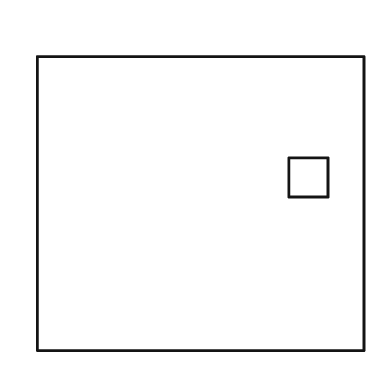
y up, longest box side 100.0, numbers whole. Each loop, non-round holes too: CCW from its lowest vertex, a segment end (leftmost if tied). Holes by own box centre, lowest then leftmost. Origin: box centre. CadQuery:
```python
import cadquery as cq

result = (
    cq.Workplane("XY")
    .moveTo(-50.0, -45.0)
    .lineTo(50.0, -45.0)
    .lineTo(50.0, 45.0)
    .lineTo(-50.0, 45.0)
    .close()
    .moveTo(27.0, 2.0)
    .lineTo(39.0, 2.0)
    .lineTo(39.0, 14.0)
    .lineTo(27.0, 14.0)
    .close()
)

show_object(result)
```